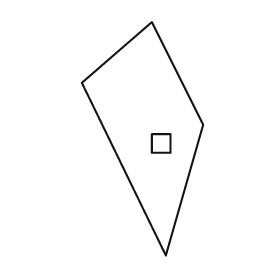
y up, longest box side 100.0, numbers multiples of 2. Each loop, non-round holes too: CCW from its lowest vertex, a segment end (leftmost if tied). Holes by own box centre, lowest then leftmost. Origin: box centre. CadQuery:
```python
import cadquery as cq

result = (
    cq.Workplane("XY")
    .moveTo(10.0, -50.0)
    .lineTo(26.0, 6.0)
    .lineTo(4.0, 50.0)
    .lineTo(-26.0, 24.0)
    .close()
    .moveTo(4.0, -6.0)
    .lineTo(12.0, -6.0)
    .lineTo(12.0, 2.0)
    .lineTo(4.0, 2.0)
    .close()
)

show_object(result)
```